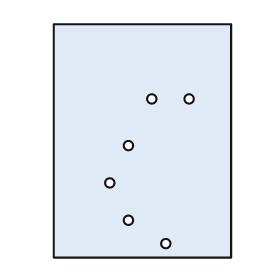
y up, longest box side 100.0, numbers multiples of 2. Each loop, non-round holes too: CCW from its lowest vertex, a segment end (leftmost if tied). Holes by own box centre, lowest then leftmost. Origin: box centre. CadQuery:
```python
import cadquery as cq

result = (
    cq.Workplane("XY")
    .moveTo(-38.0, -50.0)
    .lineTo(38.0, -50.0)
    .lineTo(38.0, 50.0)
    .lineTo(-38.0, 50.0)
    .close()
    .moveTo(10.0, -44.0)
    .circle(2.0)
    .moveTo(-6.0, -34.0)
    .circle(2.0)
    .moveTo(-14.0, -18.0)
    .circle(2.0)
    .moveTo(-6.0, -2.0)
    .circle(2.0)
    .moveTo(4.0, 18.0)
    .circle(2.0)
    .moveTo(20.0, 18.0)
    .circle(2.0)
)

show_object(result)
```